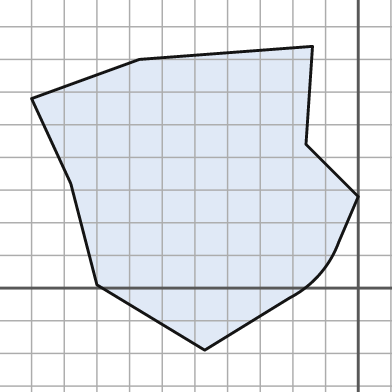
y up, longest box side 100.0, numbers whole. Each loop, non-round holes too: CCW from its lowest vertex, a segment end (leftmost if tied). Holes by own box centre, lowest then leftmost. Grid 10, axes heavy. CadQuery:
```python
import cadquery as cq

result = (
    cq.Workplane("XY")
    .moveTo(-47.0, -19.0)
    .lineTo(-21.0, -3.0)
    .threePointArc((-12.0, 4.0), (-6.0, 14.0))
    .lineTo(0.0, 28.0)
    .lineTo(-16.0, 44.0)
    .lineTo(-14.0, 74.0)
    .lineTo(-67.0, 70.0)
    .lineTo(-100.0, 58.0)
    .lineTo(-88.0, 32.0)
    .lineTo(-80.0, 1.0)
    .close()
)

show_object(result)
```